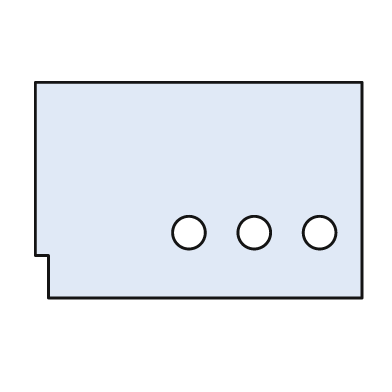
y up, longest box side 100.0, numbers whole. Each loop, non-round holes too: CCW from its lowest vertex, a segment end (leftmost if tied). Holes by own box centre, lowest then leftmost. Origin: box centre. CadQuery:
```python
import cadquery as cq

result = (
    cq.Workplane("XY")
    .moveTo(-46.0, -33.0)
    .lineTo(50.0, -33.0)
    .lineTo(50.0, 33.0)
    .lineTo(-50.0, 33.0)
    .lineTo(-50.0, -20.0)
    .lineTo(-46.0, -20.0)
    .close()
    .moveTo(-3.0, -13.0)
    .circle(5.0)
    .moveTo(17.0, -13.0)
    .circle(5.0)
    .moveTo(37.0, -13.0)
    .circle(5.0)
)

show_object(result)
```